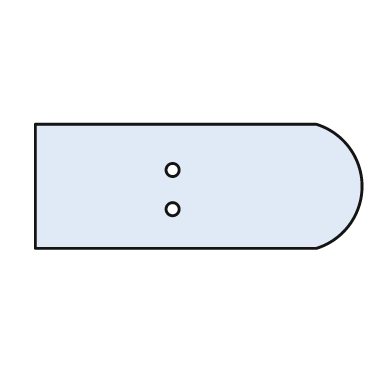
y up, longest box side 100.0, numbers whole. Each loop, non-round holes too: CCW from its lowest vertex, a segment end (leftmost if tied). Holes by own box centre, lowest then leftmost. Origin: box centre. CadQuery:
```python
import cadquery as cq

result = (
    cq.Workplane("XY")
    .moveTo(-50.0, -19.0)
    .lineTo(36.0, -19.0)
    .threePointArc((50.0, 0.0), (36.0, 19.0))
    .lineTo(-50.0, 19.0)
    .close()
    .moveTo(-8.0, -7.0)
    .circle(2.0)
    .moveTo(-8.0, 5.0)
    .circle(2.0)
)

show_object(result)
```